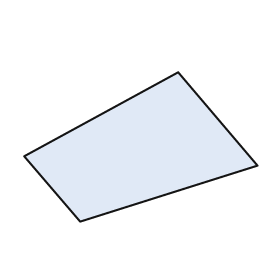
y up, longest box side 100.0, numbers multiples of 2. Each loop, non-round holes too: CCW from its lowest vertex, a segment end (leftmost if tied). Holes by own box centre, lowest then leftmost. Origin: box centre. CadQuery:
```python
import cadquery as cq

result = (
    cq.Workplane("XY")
    .moveTo(-26.0, -32.0)
    .lineTo(50.0, -8.0)
    .lineTo(16.0, 32.0)
    .lineTo(-50.0, -4.0)
    .close()
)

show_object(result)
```